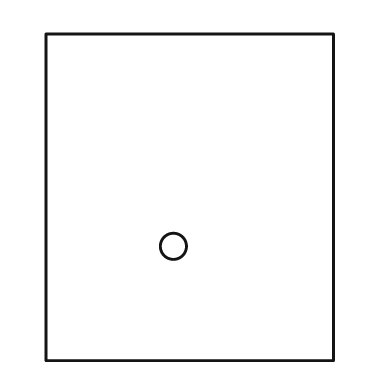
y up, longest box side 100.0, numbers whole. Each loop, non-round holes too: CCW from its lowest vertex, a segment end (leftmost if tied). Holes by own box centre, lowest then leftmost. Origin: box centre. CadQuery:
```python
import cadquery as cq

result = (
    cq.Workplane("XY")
    .moveTo(-44.0, -50.0)
    .lineTo(44.0, -50.0)
    .lineTo(44.0, 50.0)
    .lineTo(-44.0, 50.0)
    .close()
    .moveTo(-5.0, -15.0)
    .circle(4.0)
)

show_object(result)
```